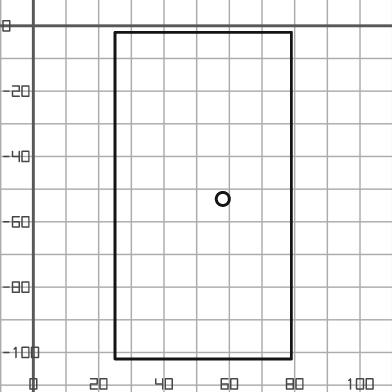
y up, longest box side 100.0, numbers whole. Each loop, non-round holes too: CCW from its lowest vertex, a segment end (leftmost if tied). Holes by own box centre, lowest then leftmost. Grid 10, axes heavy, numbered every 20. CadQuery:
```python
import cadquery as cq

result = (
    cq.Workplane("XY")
    .moveTo(25.0, -102.0)
    .lineTo(79.0, -102.0)
    .lineTo(79.0, -2.0)
    .lineTo(25.0, -2.0)
    .close()
    .moveTo(58.0, -53.0)
    .circle(2.0)
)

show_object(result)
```